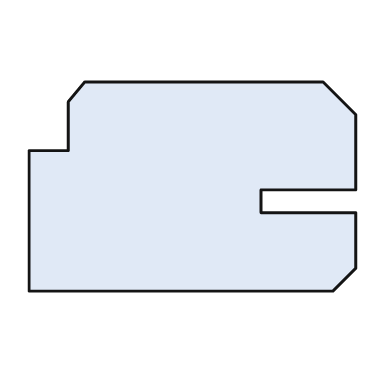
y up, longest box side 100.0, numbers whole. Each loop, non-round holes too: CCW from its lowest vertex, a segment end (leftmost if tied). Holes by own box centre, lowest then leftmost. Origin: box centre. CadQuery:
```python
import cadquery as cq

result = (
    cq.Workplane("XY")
    .moveTo(-50.0, -32.0)
    .lineTo(43.0, -32.0)
    .lineTo(50.0, -25.0)
    .lineTo(50.0, -8.0)
    .lineTo(21.0, -8.0)
    .lineTo(21.0, -1.0)
    .lineTo(50.0, -1.0)
    .lineTo(50.0, 22.0)
    .lineTo(40.0, 32.0)
    .lineTo(-33.0, 32.0)
    .lineTo(-38.0, 26.0)
    .lineTo(-38.0, 11.0)
    .lineTo(-50.0, 11.0)
    .close()
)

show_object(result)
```